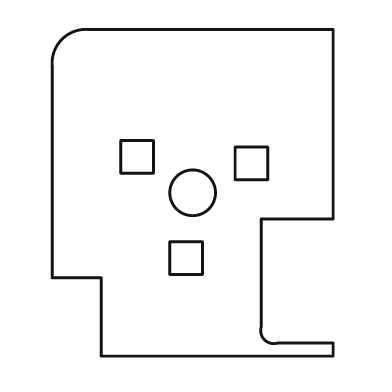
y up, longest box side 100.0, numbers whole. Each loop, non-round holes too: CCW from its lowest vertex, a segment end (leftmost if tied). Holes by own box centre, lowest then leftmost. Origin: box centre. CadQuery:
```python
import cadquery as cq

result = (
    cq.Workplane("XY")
    .moveTo(-28.0, -50.0)
    .lineTo(43.0, -50.0)
    .lineTo(43.0, -46.0)
    .lineTo(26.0, -46.0)
    .threePointArc((22.0, -45.0), (21.0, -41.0))
    .lineTo(21.0, -8.0)
    .lineTo(43.0, -8.0)
    .lineTo(43.0, 50.0)
    .lineTo(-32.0, 50.0)
    .threePointArc((-40.0, 47.0), (-43.0, 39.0))
    .lineTo(-43.0, -26.0)
    .lineTo(-28.0, -26.0)
    .close()
    .moveTo(-7.0, -25.0)
    .lineTo(3.0, -25.0)
    .lineTo(3.0, -15.0)
    .lineTo(-7.0, -15.0)
    .close()
    .moveTo(0.0, 0.0)
    .circle(7.0)
    .moveTo(13.0, 4.0)
    .lineTo(23.0, 4.0)
    .lineTo(23.0, 14.0)
    .lineTo(13.0, 14.0)
    .close()
    .moveTo(-22.0, 6.0)
    .lineTo(-12.0, 6.0)
    .lineTo(-12.0, 16.0)
    .lineTo(-22.0, 16.0)
    .close()
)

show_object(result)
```